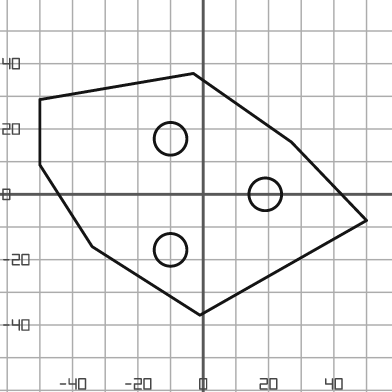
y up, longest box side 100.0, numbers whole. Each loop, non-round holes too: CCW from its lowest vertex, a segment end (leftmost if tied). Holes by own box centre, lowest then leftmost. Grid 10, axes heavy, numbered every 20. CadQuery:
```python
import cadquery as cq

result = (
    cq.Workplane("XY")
    .moveTo(-1.0, -37.0)
    .lineTo(50.0, -8.0)
    .lineTo(27.0, 16.0)
    .lineTo(-3.0, 37.0)
    .lineTo(-50.0, 29.0)
    .lineTo(-50.0, 9.0)
    .lineTo(-34.0, -16.0)
    .close()
    .moveTo(-10.0, -17.0)
    .circle(5.0)
    .moveTo(19.0, 0.0)
    .circle(5.0)
    .moveTo(-10.0, 17.0)
    .circle(5.0)
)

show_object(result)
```